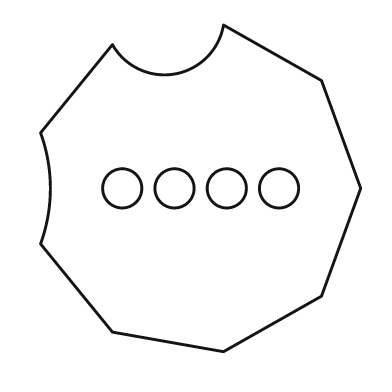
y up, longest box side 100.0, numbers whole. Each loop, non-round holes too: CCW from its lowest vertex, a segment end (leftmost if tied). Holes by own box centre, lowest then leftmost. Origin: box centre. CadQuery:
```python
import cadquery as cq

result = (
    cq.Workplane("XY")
    .moveTo(7.0, -50.0)
    .lineTo(37.0, -33.0)
    .lineTo(49.0, 0.0)
    .lineTo(37.0, 33.0)
    .lineTo(7.0, 50.0)
    .threePointArc((-8.0, 35.0), (-27.0, 44.0))
    .lineTo(-49.0, 17.0)
    .threePointArc((-46.0, 0.0), (-49.0, -17.0))
    .lineTo(-27.0, -44.0)
    .close()
    .moveTo(-24.0, 0.0)
    .circle(6.0)
    .moveTo(-8.0, 0.0)
    .circle(6.0)
    .moveTo(8.0, 0.0)
    .circle(6.0)
    .moveTo(24.0, 0.0)
    .circle(6.0)
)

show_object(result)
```